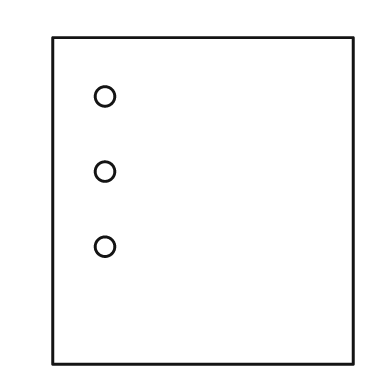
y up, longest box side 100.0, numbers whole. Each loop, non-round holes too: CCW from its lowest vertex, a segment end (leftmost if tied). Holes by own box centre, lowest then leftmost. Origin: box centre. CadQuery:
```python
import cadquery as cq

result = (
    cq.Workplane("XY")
    .moveTo(-46.0, -50.0)
    .lineTo(46.0, -50.0)
    .lineTo(46.0, 50.0)
    .lineTo(-46.0, 50.0)
    .close()
    .moveTo(-30.0, -14.0)
    .circle(3.0)
    .moveTo(-30.0, 9.0)
    .circle(3.0)
    .moveTo(-30.0, 32.0)
    .circle(3.0)
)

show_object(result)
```